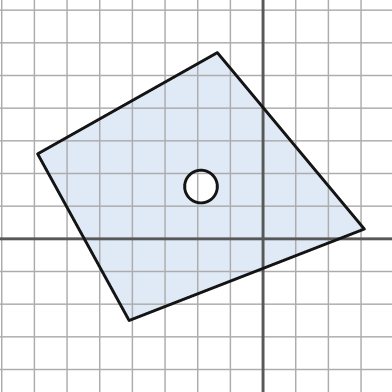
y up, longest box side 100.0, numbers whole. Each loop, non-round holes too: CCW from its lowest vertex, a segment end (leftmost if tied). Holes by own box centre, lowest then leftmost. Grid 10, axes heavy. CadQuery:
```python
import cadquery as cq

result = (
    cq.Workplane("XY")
    .moveTo(-41.0, -25.0)
    .lineTo(31.0, 3.0)
    .lineTo(-14.0, 57.0)
    .lineTo(-69.0, 26.0)
    .close()
    .moveTo(-19.0, 16.0)
    .circle(5.0)
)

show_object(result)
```